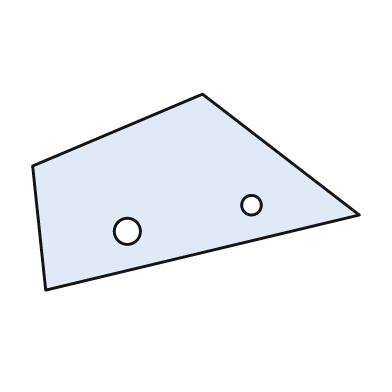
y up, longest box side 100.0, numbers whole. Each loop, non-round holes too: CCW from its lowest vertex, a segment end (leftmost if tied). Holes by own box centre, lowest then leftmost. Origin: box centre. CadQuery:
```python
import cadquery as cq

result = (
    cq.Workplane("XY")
    .moveTo(-46.0, -30.0)
    .lineTo(50.0, -7.0)
    .lineTo(2.0, 30.0)
    .lineTo(-50.0, 8.0)
    .close()
    .moveTo(-21.0, -12.0)
    .circle(4.0)
    .moveTo(17.0, -4.0)
    .circle(3.0)
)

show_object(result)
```